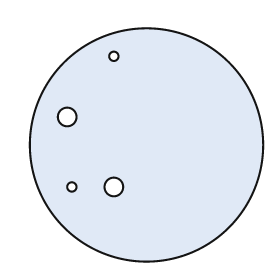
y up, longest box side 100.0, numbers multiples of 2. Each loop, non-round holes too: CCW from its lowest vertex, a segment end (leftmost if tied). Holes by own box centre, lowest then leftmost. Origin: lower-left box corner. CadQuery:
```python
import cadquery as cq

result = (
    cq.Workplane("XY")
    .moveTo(50.0, 50.0)
    .circle(50.0)
    .moveTo(18.0, 32.0)
    .circle(2.0)
    .moveTo(36.0, 32.0)
    .circle(4.0)
    .moveTo(16.0, 62.0)
    .circle(4.0)
    .moveTo(36.0, 88.0)
    .circle(2.0)
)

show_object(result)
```